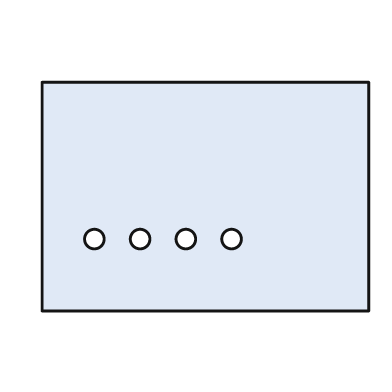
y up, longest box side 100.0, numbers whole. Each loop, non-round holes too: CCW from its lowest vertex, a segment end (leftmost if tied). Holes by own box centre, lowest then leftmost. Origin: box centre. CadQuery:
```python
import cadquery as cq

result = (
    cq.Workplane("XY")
    .moveTo(-50.0, -35.0)
    .lineTo(50.0, -35.0)
    .lineTo(50.0, 35.0)
    .lineTo(-50.0, 35.0)
    .close()
    .moveTo(-34.0, -13.0)
    .circle(3.0)
    .moveTo(-20.0, -13.0)
    .circle(3.0)
    .moveTo(-6.0, -13.0)
    .circle(3.0)
    .moveTo(8.0, -13.0)
    .circle(3.0)
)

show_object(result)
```